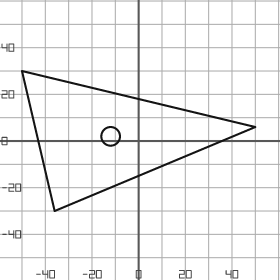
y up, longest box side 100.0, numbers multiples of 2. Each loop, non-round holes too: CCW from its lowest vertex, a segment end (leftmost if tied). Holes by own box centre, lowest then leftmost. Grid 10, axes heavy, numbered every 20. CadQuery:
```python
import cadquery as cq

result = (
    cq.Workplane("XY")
    .moveTo(-36.0, -30.0)
    .lineTo(50.0, 6.0)
    .lineTo(-50.0, 30.0)
    .close()
    .moveTo(-12.0, 2.0)
    .circle(4.0)
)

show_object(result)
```